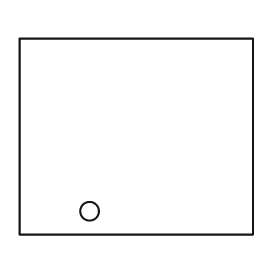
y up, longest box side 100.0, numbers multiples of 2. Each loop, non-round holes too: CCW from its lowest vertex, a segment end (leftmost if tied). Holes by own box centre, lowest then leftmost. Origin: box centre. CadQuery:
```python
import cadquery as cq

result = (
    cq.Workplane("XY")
    .moveTo(-50.0, -42.0)
    .lineTo(50.0, -42.0)
    .lineTo(50.0, 42.0)
    .lineTo(-50.0, 42.0)
    .close()
    .moveTo(-20.0, -32.0)
    .circle(4.0)
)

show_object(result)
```